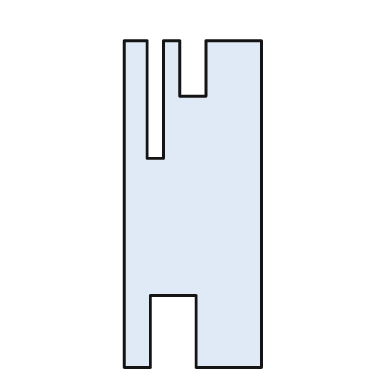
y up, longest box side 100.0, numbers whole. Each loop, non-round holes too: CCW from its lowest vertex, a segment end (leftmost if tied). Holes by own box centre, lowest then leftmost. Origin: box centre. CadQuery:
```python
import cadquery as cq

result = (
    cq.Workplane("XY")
    .moveTo(-21.0, -50.0)
    .lineTo(-13.0, -50.0)
    .lineTo(-13.0, -28.0)
    .lineTo(1.0, -28.0)
    .lineTo(1.0, -50.0)
    .lineTo(21.0, -50.0)
    .lineTo(21.0, 50.0)
    .lineTo(4.0, 50.0)
    .lineTo(4.0, 33.0)
    .lineTo(-4.0, 33.0)
    .lineTo(-4.0, 50.0)
    .lineTo(-9.0, 50.0)
    .lineTo(-9.0, 14.0)
    .lineTo(-14.0, 14.0)
    .lineTo(-14.0, 50.0)
    .lineTo(-21.0, 50.0)
    .close()
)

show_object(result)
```